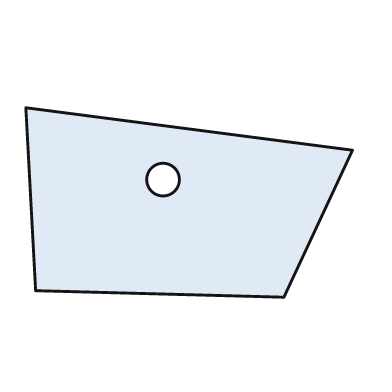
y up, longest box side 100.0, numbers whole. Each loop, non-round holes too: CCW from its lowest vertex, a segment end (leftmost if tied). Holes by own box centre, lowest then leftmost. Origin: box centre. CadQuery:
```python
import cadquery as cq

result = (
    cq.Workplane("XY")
    .moveTo(29.0, -29.0)
    .lineTo(50.0, 16.0)
    .lineTo(-50.0, 29.0)
    .lineTo(-47.0, -27.0)
    .close()
    .moveTo(-8.0, 7.0)
    .circle(5.0)
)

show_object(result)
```